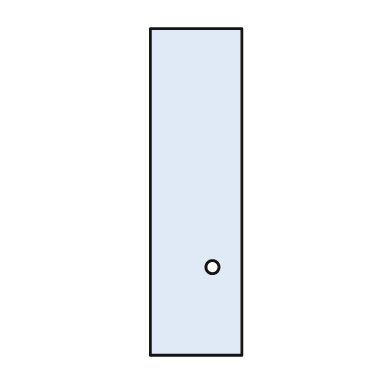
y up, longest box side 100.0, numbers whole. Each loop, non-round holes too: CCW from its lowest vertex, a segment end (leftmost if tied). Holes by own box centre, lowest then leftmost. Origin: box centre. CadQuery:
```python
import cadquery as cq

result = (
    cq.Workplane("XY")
    .moveTo(-14.0, -50.0)
    .lineTo(14.0, -50.0)
    .lineTo(14.0, 50.0)
    .lineTo(-14.0, 50.0)
    .close()
    .moveTo(5.0, -23.0)
    .circle(2.0)
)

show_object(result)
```